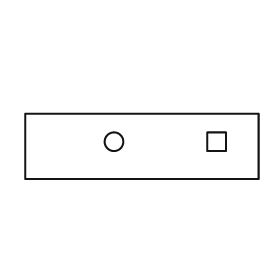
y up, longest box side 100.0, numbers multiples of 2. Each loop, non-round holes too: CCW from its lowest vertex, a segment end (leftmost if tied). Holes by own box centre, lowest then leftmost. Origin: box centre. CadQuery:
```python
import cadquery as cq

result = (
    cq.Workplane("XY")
    .moveTo(-50.0, -14.0)
    .lineTo(50.0, -14.0)
    .lineTo(50.0, 14.0)
    .lineTo(-50.0, 14.0)
    .close()
    .moveTo(-12.0, 2.0)
    .circle(4.0)
    .moveTo(28.0, -2.0)
    .lineTo(36.0, -2.0)
    .lineTo(36.0, 6.0)
    .lineTo(28.0, 6.0)
    .close()
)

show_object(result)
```